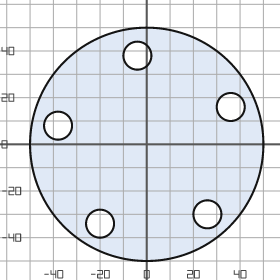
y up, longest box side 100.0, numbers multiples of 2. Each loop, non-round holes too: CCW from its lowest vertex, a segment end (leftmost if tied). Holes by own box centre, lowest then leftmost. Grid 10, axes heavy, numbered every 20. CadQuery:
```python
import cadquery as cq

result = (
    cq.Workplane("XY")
    .moveTo(0.0, 0.0)
    .circle(50.0)
    .moveTo(-20.0, -34.0)
    .circle(6.0)
    .moveTo(26.0, -30.0)
    .circle(6.0)
    .moveTo(-38.0, 8.0)
    .circle(6.0)
    .moveTo(36.0, 16.0)
    .circle(6.0)
    .moveTo(-4.0, 38.0)
    .circle(6.0)
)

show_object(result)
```